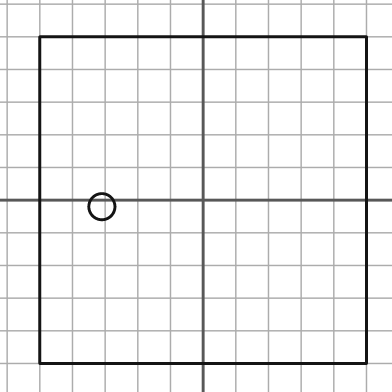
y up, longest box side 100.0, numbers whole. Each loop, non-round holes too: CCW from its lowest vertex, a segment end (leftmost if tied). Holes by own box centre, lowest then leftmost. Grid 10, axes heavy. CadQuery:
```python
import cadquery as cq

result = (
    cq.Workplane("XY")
    .moveTo(-50.0, -50.0)
    .lineTo(50.0, -50.0)
    .lineTo(50.0, 50.0)
    .lineTo(-50.0, 50.0)
    .close()
    .moveTo(-31.0, -2.0)
    .circle(4.0)
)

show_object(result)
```